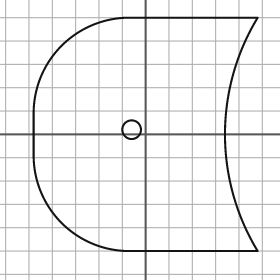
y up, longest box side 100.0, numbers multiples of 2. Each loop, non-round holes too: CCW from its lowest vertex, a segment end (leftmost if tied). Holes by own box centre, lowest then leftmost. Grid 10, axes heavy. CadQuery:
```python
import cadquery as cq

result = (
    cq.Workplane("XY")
    .moveTo(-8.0, -50.0)
    .lineTo(48.0, -50.0)
    .threePointArc((34.0, 0.0), (48.0, 50.0))
    .lineTo(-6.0, 50.0)
    .threePointArc((-36.0, 38.0), (-48.0, 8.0))
    .lineTo(-48.0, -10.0)
    .threePointArc((-36.0, -38.0), (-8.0, -50.0))
    .close()
    .moveTo(-6.0, 2.0)
    .circle(4.0)
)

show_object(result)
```